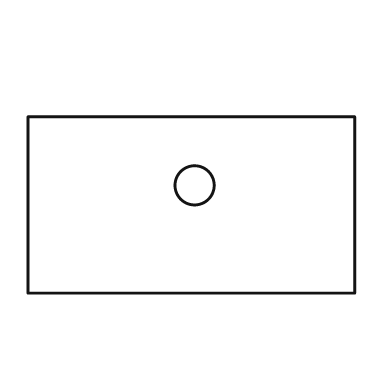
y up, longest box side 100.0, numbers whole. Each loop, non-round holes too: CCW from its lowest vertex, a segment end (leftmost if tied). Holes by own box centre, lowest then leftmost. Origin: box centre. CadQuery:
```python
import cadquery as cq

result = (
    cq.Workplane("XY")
    .moveTo(-50.0, -27.0)
    .lineTo(50.0, -27.0)
    .lineTo(50.0, 27.0)
    .lineTo(-50.0, 27.0)
    .close()
    .moveTo(1.0, 6.0)
    .circle(6.0)
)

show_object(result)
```